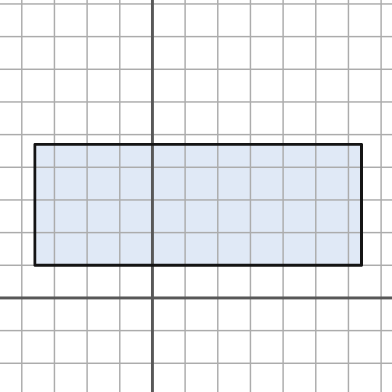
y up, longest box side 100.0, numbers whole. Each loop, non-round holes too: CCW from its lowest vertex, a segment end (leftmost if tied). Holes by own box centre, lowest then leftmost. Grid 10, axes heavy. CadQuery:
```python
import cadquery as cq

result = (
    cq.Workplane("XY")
    .moveTo(-36.0, 10.0)
    .lineTo(64.0, 10.0)
    .lineTo(64.0, 47.0)
    .lineTo(-36.0, 47.0)
    .close()
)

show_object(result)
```